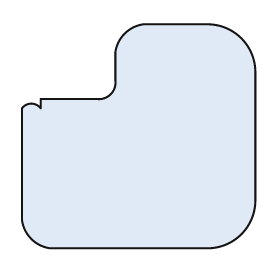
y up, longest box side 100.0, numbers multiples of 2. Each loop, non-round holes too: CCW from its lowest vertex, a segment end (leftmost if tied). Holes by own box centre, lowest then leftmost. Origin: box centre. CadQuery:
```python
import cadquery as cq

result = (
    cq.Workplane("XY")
    .moveTo(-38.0, -48.0)
    .lineTo(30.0, -48.0)
    .threePointArc((44.0, -42.0), (50.0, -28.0))
    .lineTo(50.0, 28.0)
    .threePointArc((44.0, 42.0), (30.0, 48.0))
    .lineTo(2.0, 48.0)
    .threePointArc((-6.0, 44.0), (-10.0, 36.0))
    .lineTo(-10.0, 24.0)
    .threePointArc((-12.0, 18.0), (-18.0, 16.0))
    .lineTo(-42.0, 16.0)
    .lineTo(-42.0, 12.0)
    .threePointArc((-46.0, 14.0), (-50.0, 12.0))
    .lineTo(-50.0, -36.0)
    .threePointArc((-46.0, -44.0), (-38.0, -48.0))
    .close()
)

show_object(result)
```